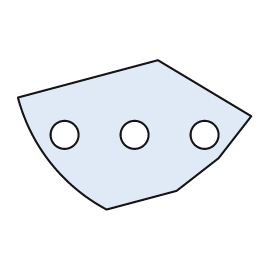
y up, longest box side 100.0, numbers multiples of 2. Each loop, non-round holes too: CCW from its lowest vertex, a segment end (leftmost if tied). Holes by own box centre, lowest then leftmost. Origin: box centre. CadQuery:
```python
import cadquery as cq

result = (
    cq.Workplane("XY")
    .moveTo(-12.0, -32.0)
    .lineTo(18.0, -24.0)
    .lineTo(36.0, -10.0)
    .lineTo(50.0, 8.0)
    .lineTo(10.0, 32.0)
    .lineTo(-50.0, 16.0)
    .threePointArc((-36.0, -12.0), (-12.0, -32.0))
    .close()
    .moveTo(-30.0, 0.0)
    .circle(6.0)
    .moveTo(0.0, 0.0)
    .circle(6.0)
    .moveTo(30.0, 0.0)
    .circle(6.0)
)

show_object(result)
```